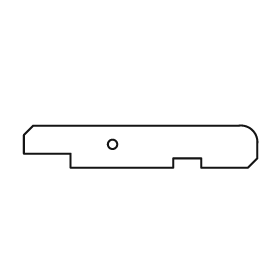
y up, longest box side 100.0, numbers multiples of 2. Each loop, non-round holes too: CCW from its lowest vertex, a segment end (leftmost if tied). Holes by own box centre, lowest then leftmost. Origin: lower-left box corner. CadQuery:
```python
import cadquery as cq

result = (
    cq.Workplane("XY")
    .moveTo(20.0, 0.0)
    .lineTo(64.0, 0.0)
    .lineTo(64.0, 4.0)
    .lineTo(76.0, 4.0)
    .lineTo(76.0, 0.0)
    .lineTo(96.0, 0.0)
    .lineTo(100.0, 4.0)
    .lineTo(100.0, 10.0)
    .threePointArc((98.0, 16.0), (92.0, 18.0))
    .lineTo(4.0, 18.0)
    .lineTo(0.0, 14.0)
    .lineTo(0.0, 6.0)
    .lineTo(20.0, 6.0)
    .close()
    .moveTo(38.0, 10.0)
    .circle(2.0)
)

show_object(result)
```